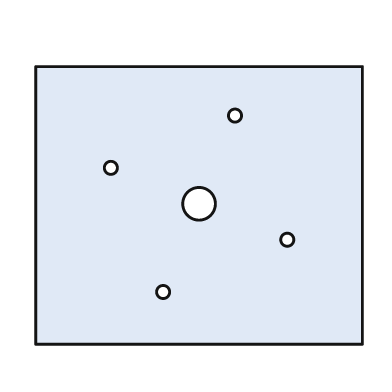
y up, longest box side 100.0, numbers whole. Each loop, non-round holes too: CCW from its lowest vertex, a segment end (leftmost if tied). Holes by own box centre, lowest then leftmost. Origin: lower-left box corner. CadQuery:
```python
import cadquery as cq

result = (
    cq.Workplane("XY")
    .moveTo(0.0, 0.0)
    .lineTo(100.0, 0.0)
    .lineTo(100.0, 85.0)
    .lineTo(0.0, 85.0)
    .close()
    .moveTo(39.0, 16.0)
    .circle(2.0)
    .moveTo(77.0, 32.0)
    .circle(2.0)
    .moveTo(50.0, 43.0)
    .circle(5.0)
    .moveTo(23.0, 54.0)
    .circle(2.0)
    .moveTo(61.0, 70.0)
    .circle(2.0)
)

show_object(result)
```